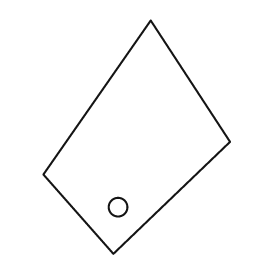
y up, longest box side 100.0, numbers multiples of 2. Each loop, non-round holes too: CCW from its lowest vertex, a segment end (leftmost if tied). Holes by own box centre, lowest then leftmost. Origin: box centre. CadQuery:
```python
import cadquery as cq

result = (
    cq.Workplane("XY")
    .moveTo(-10.0, -50.0)
    .lineTo(40.0, -2.0)
    .lineTo(6.0, 50.0)
    .lineTo(-40.0, -16.0)
    .close()
    .moveTo(-8.0, -30.0)
    .circle(4.0)
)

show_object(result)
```